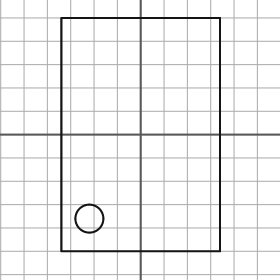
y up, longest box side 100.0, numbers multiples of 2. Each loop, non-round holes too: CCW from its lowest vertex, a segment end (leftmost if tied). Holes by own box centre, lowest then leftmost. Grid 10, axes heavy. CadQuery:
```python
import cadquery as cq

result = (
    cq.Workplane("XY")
    .moveTo(-34.0, -50.0)
    .lineTo(34.0, -50.0)
    .lineTo(34.0, 50.0)
    .lineTo(-34.0, 50.0)
    .close()
    .moveTo(-22.0, -36.0)
    .circle(6.0)
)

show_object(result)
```